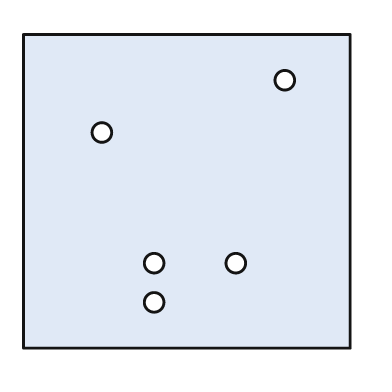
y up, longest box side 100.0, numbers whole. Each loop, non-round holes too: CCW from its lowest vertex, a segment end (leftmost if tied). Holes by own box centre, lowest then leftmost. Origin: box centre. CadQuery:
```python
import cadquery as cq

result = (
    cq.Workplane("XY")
    .moveTo(-50.0, -48.0)
    .lineTo(50.0, -48.0)
    .lineTo(50.0, 48.0)
    .lineTo(-50.0, 48.0)
    .close()
    .moveTo(-10.0, -34.0)
    .circle(3.0)
    .moveTo(-10.0, -22.0)
    .circle(3.0)
    .moveTo(15.0, -22.0)
    .circle(3.0)
    .moveTo(-26.0, 18.0)
    .circle(3.0)
    .moveTo(30.0, 34.0)
    .circle(3.0)
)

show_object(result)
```